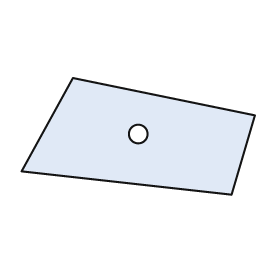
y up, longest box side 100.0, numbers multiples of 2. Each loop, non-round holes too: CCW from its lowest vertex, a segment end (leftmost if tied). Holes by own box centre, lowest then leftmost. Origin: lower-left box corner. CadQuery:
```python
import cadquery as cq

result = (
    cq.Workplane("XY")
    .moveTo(90.0, 0.0)
    .lineTo(100.0, 34.0)
    .lineTo(22.0, 50.0)
    .lineTo(0.0, 10.0)
    .close()
    .moveTo(50.0, 26.0)
    .circle(4.0)
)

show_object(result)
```